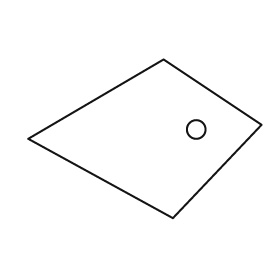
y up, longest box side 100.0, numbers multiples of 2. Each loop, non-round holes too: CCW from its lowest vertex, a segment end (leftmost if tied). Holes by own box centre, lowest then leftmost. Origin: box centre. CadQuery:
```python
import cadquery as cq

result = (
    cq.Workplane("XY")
    .moveTo(12.0, -34.0)
    .lineTo(50.0, 6.0)
    .lineTo(8.0, 34.0)
    .lineTo(-50.0, 0.0)
    .close()
    .moveTo(22.0, 4.0)
    .circle(4.0)
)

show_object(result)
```